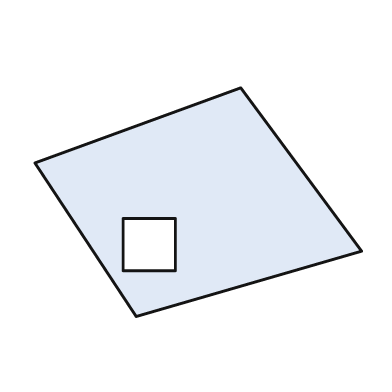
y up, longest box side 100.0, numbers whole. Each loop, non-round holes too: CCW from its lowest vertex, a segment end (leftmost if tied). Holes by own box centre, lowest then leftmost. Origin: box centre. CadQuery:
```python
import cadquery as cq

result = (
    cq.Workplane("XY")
    .moveTo(-19.0, -35.0)
    .lineTo(50.0, -15.0)
    .lineTo(13.0, 35.0)
    .lineTo(-50.0, 12.0)
    .close()
    .moveTo(-23.0, -21.0)
    .lineTo(-7.0, -21.0)
    .lineTo(-7.0, -5.0)
    .lineTo(-23.0, -5.0)
    .close()
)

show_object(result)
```